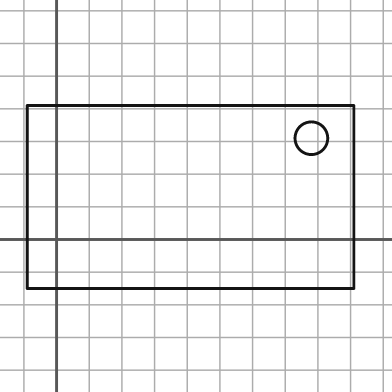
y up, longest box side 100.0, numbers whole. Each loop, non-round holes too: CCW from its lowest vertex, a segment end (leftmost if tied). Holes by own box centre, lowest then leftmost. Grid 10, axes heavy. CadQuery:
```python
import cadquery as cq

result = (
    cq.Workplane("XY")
    .moveTo(-9.0, -15.0)
    .lineTo(91.0, -15.0)
    .lineTo(91.0, 41.0)
    .lineTo(-9.0, 41.0)
    .close()
    .moveTo(78.0, 31.0)
    .circle(5.0)
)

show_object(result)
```